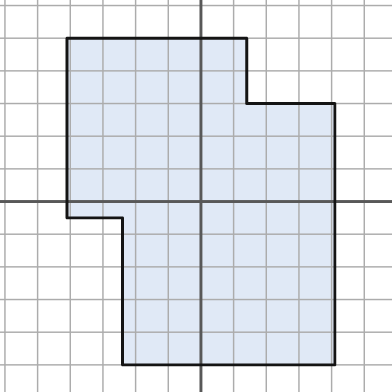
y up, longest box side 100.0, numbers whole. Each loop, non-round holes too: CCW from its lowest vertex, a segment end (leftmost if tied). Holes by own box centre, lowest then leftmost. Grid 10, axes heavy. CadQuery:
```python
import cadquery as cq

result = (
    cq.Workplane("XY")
    .moveTo(-24.0, -50.0)
    .lineTo(41.0, -50.0)
    .lineTo(41.0, 30.0)
    .lineTo(14.0, 30.0)
    .lineTo(14.0, 50.0)
    .lineTo(-41.0, 50.0)
    .lineTo(-41.0, -5.0)
    .lineTo(-24.0, -5.0)
    .close()
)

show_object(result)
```